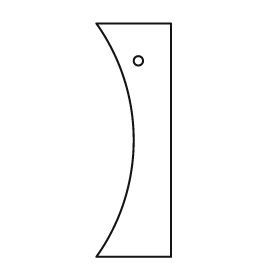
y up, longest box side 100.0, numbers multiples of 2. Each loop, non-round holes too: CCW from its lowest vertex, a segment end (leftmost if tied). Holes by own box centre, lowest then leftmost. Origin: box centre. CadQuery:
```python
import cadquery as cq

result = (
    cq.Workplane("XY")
    .moveTo(-16.0, -50.0)
    .lineTo(16.0, -50.0)
    .lineTo(16.0, 50.0)
    .lineTo(-16.0, 50.0)
    .threePointArc((0.0, 0.0), (-16.0, -50.0))
    .close()
    .moveTo(2.0, 34.0)
    .circle(2.0)
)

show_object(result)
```